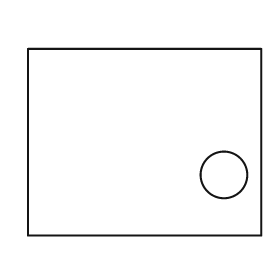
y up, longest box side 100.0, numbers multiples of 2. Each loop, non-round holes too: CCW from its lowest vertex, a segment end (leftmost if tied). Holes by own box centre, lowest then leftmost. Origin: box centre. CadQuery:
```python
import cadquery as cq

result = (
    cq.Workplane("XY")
    .moveTo(-50.0, -40.0)
    .lineTo(50.0, -40.0)
    .lineTo(50.0, 40.0)
    .lineTo(-50.0, 40.0)
    .close()
    .moveTo(34.0, -14.0)
    .circle(10.0)
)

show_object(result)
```